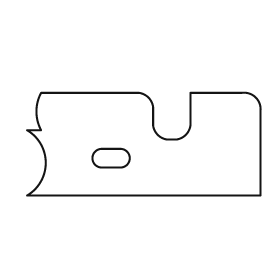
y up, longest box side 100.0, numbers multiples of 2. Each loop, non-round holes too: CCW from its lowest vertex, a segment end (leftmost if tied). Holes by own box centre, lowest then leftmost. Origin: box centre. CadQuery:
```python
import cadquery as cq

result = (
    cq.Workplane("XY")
    .moveTo(-50.0, -22.0)
    .lineTo(50.0, -22.0)
    .lineTo(50.0, 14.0)
    .threePointArc((48.0, 20.0), (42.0, 22.0))
    .lineTo(20.0, 22.0)
    .lineTo(20.0, 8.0)
    .threePointArc((18.0, 4.0), (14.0, 2.0))
    .lineTo(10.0, 2.0)
    .threePointArc((6.0, 4.0), (4.0, 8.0))
    .lineTo(4.0, 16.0)
    .threePointArc((2.0, 20.0), (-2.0, 22.0))
    .lineTo(-44.0, 22.0)
    .threePointArc((-46.0, 14.0), (-44.0, 6.0))
    .lineTo(-50.0, 6.0)
    .threePointArc((-42.0, -8.0), (-50.0, -22.0))
    .close()
    .moveTo(-18.0, -10.0)
    .lineTo(-10.0, -10.0)
    .threePointArc((-6.0, -6.0), (-10.0, -2.0))
    .lineTo(-18.0, -2.0)
    .threePointArc((-22.0, -6.0), (-18.0, -10.0))
    .close()
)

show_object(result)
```